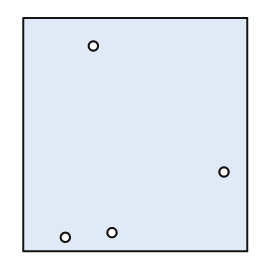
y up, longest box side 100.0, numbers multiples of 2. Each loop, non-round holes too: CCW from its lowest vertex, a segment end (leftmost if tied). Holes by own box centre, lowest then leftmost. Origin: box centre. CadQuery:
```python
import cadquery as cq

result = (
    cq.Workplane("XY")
    .moveTo(-48.0, -50.0)
    .lineTo(48.0, -50.0)
    .lineTo(48.0, 50.0)
    .lineTo(-48.0, 50.0)
    .close()
    .moveTo(-30.0, -44.0)
    .circle(2.0)
    .moveTo(-10.0, -42.0)
    .circle(2.0)
    .moveTo(38.0, -16.0)
    .circle(2.0)
    .moveTo(-18.0, 38.0)
    .circle(2.0)
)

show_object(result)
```